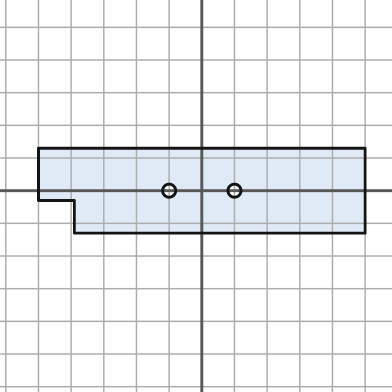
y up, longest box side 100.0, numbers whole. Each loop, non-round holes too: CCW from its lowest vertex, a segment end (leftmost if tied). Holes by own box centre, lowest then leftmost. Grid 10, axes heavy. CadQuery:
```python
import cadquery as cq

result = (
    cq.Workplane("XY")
    .moveTo(-39.0, -13.0)
    .lineTo(50.0, -13.0)
    .lineTo(50.0, 13.0)
    .lineTo(-50.0, 13.0)
    .lineTo(-50.0, -3.0)
    .lineTo(-39.0, -3.0)
    .close()
    .moveTo(-10.0, 0.0)
    .circle(2.0)
    .moveTo(10.0, 0.0)
    .circle(2.0)
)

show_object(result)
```